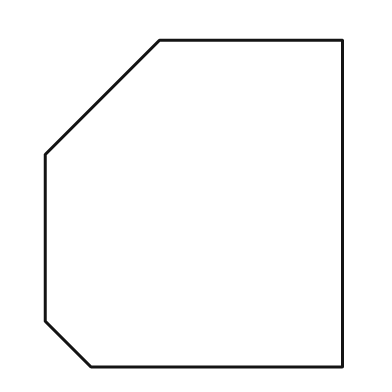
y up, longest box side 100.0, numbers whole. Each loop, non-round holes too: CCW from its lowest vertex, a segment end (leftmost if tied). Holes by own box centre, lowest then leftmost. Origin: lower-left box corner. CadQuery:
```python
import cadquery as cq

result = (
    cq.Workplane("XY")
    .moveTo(14.0, 0.0)
    .lineTo(91.0, 0.0)
    .lineTo(91.0, 100.0)
    .lineTo(35.0, 100.0)
    .lineTo(0.0, 65.0)
    .lineTo(0.0, 14.0)
    .close()
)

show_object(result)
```